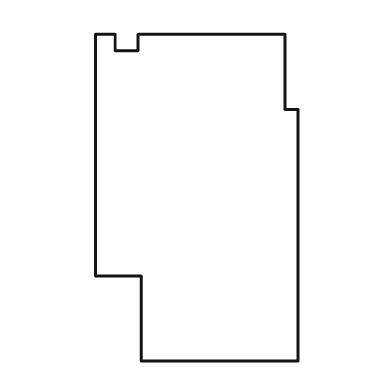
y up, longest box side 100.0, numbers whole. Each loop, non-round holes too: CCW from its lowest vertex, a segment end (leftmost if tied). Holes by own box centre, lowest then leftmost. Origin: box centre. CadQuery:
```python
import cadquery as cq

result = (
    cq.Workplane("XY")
    .moveTo(-17.0, -50.0)
    .lineTo(31.0, -50.0)
    .lineTo(31.0, 27.0)
    .lineTo(27.0, 27.0)
    .lineTo(27.0, 50.0)
    .lineTo(-18.0, 50.0)
    .lineTo(-18.0, 45.0)
    .lineTo(-25.0, 45.0)
    .lineTo(-25.0, 50.0)
    .lineTo(-31.0, 50.0)
    .lineTo(-31.0, -24.0)
    .lineTo(-17.0, -24.0)
    .close()
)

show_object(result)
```